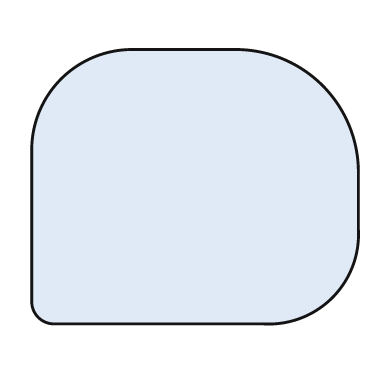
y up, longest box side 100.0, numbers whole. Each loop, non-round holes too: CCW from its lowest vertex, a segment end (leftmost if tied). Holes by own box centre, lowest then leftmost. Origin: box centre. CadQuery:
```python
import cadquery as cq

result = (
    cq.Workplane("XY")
    .moveTo(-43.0, -42.0)
    .lineTo(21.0, -42.0)
    .threePointArc((42.0, -34.0), (50.0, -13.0))
    .lineTo(50.0, 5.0)
    .threePointArc((39.0, 31.0), (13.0, 42.0))
    .lineTo(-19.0, 42.0)
    .threePointArc((-41.0, 33.0), (-50.0, 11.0))
    .lineTo(-50.0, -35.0)
    .threePointArc((-48.0, -40.0), (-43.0, -42.0))
    .close()
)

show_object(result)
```